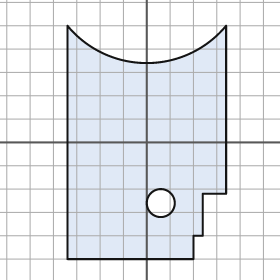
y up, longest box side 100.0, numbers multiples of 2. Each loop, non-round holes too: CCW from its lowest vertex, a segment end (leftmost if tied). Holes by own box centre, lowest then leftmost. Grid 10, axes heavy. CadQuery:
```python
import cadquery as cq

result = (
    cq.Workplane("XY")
    .moveTo(-34.0, -50.0)
    .lineTo(20.0, -50.0)
    .lineTo(20.0, -40.0)
    .lineTo(24.0, -40.0)
    .lineTo(24.0, -22.0)
    .lineTo(34.0, -22.0)
    .lineTo(34.0, 50.0)
    .threePointArc((0.0, 34.0), (-34.0, 50.0))
    .close()
    .moveTo(6.0, -26.0)
    .circle(6.0)
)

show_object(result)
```